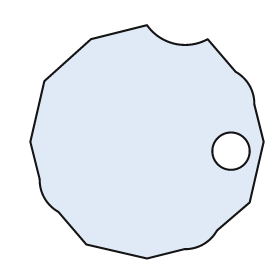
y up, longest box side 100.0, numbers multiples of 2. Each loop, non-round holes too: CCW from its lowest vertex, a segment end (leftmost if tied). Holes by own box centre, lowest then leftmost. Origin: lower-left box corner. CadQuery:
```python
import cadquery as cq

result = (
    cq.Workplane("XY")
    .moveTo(50.0, 0.0)
    .lineTo(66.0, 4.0)
    .threePointArc((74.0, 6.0), (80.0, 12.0))
    .lineTo(94.0, 24.0)
    .lineTo(100.0, 50.0)
    .lineTo(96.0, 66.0)
    .threePointArc((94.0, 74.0), (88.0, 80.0))
    .lineTo(76.0, 94.0)
    .threePointArc((62.0, 92.0), (50.0, 100.0))
    .lineTo(26.0, 94.0)
    .lineTo(6.0, 76.0)
    .lineTo(0.0, 50.0)
    .lineTo(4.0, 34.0)
    .threePointArc((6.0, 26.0), (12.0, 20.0))
    .lineTo(24.0, 6.0)
    .close()
    .moveTo(86.0, 46.0)
    .circle(8.0)
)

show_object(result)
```